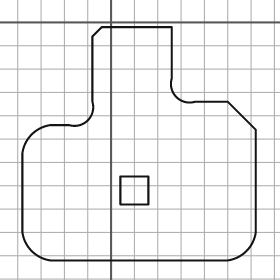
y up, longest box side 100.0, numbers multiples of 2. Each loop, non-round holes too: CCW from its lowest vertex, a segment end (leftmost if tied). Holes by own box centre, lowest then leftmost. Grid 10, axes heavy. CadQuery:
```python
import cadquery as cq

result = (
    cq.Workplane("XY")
    .moveTo(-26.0, -102.0)
    .lineTo(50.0, -102.0)
    .threePointArc((58.0, -98.0), (62.0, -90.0))
    .lineTo(62.0, -46.0)
    .lineTo(50.0, -34.0)
    .lineTo(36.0, -34.0)
    .threePointArc((28.0, -32.0), (26.0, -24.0))
    .lineTo(26.0, -2.0)
    .lineTo(-4.0, -2.0)
    .lineTo(-8.0, -6.0)
    .lineTo(-8.0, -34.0)
    .threePointArc((-10.0, -42.0), (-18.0, -44.0))
    .lineTo(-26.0, -44.0)
    .threePointArc((-34.0, -48.0), (-38.0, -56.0))
    .lineTo(-38.0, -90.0)
    .threePointArc((-34.0, -98.0), (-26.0, -102.0))
    .close()
    .moveTo(4.0, -78.0)
    .lineTo(16.0, -78.0)
    .lineTo(16.0, -66.0)
    .lineTo(4.0, -66.0)
    .close()
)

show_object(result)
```